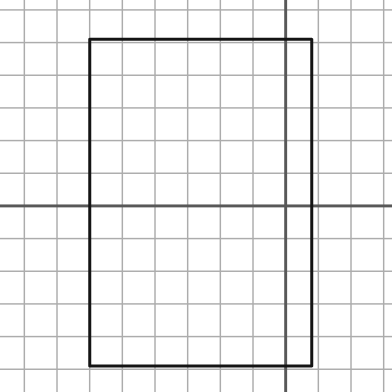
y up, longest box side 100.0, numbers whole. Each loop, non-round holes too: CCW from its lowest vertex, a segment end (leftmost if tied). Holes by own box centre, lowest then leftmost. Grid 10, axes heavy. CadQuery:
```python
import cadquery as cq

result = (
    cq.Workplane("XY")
    .moveTo(-60.0, -49.0)
    .lineTo(8.0, -49.0)
    .lineTo(8.0, 51.0)
    .lineTo(-60.0, 51.0)
    .close()
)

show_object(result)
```